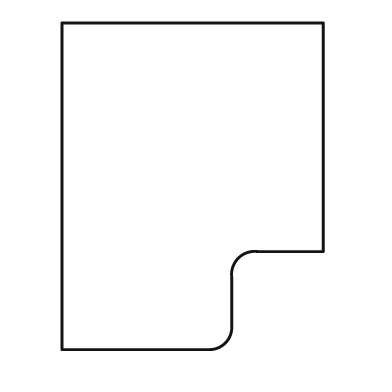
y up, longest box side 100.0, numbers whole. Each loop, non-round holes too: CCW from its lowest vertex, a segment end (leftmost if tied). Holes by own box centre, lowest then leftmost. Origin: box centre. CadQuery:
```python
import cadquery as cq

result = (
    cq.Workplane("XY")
    .moveTo(-40.0, -50.0)
    .lineTo(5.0, -50.0)
    .threePointArc((10.0, -48.0), (12.0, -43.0))
    .lineTo(12.0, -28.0)
    .threePointArc((14.0, -22.0), (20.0, -20.0))
    .lineTo(40.0, -20.0)
    .lineTo(40.0, 50.0)
    .lineTo(-40.0, 50.0)
    .close()
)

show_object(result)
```